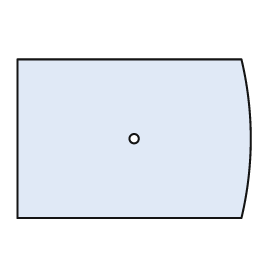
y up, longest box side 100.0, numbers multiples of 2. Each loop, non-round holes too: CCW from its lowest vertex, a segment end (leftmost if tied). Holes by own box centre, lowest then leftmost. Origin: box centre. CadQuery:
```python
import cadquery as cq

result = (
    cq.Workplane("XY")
    .moveTo(-50.0, -34.0)
    .lineTo(46.0, -34.0)
    .threePointArc((50.0, 0.0), (46.0, 34.0))
    .lineTo(-50.0, 34.0)
    .close()
    .moveTo(0.0, 0.0)
    .circle(2.0)
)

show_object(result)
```